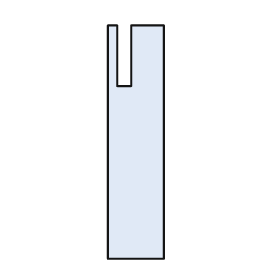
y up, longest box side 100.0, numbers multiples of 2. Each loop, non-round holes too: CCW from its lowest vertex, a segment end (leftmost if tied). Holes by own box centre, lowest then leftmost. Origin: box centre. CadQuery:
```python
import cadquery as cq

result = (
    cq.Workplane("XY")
    .moveTo(-12.0, -50.0)
    .lineTo(12.0, -50.0)
    .lineTo(12.0, 50.0)
    .lineTo(-2.0, 50.0)
    .lineTo(-2.0, 24.0)
    .lineTo(-8.0, 24.0)
    .lineTo(-8.0, 50.0)
    .lineTo(-12.0, 50.0)
    .close()
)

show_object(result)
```